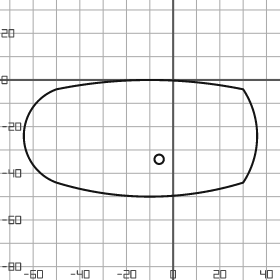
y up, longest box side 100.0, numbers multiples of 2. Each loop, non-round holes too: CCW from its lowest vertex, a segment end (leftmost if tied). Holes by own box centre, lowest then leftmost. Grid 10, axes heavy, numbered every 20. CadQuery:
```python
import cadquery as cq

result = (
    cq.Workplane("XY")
    .moveTo(-50.0, -44.0)
    .threePointArc((-10.0, -50.0), (30.0, -44.0))
    .threePointArc((36.0, -24.0), (30.0, -4.0))
    .threePointArc((-10.0, 0.0), (-50.0, -4.0))
    .threePointArc((-64.0, -24.0), (-50.0, -44.0))
    .close()
    .moveTo(-6.0, -34.0)
    .circle(2.0)
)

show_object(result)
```